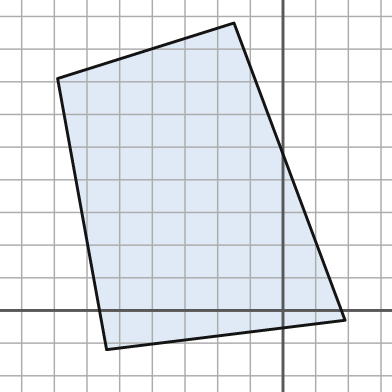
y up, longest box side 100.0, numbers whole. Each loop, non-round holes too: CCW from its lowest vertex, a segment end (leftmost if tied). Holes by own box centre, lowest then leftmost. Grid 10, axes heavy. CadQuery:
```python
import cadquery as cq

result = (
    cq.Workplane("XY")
    .moveTo(-54.0, -12.0)
    .lineTo(19.0, -3.0)
    .lineTo(-15.0, 88.0)
    .lineTo(-69.0, 71.0)
    .close()
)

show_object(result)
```